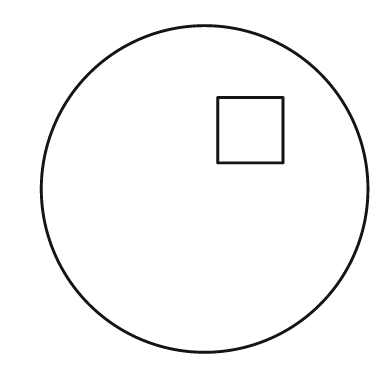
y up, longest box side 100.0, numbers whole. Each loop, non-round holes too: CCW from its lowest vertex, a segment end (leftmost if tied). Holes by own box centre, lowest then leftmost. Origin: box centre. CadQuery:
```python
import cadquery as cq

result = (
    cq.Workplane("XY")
    .moveTo(0.0, 0.0)
    .circle(50.0)
    .moveTo(4.0, 8.0)
    .lineTo(24.0, 8.0)
    .lineTo(24.0, 28.0)
    .lineTo(4.0, 28.0)
    .close()
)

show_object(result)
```